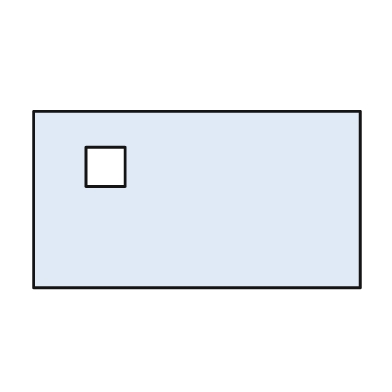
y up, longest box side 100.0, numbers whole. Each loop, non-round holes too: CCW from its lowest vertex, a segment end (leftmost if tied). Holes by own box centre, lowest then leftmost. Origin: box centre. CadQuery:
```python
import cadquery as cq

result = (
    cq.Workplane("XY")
    .moveTo(-50.0, -27.0)
    .lineTo(50.0, -27.0)
    .lineTo(50.0, 27.0)
    .lineTo(-50.0, 27.0)
    .close()
    .moveTo(-34.0, 4.0)
    .lineTo(-22.0, 4.0)
    .lineTo(-22.0, 16.0)
    .lineTo(-34.0, 16.0)
    .close()
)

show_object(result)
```